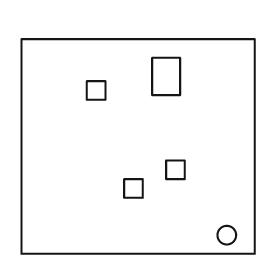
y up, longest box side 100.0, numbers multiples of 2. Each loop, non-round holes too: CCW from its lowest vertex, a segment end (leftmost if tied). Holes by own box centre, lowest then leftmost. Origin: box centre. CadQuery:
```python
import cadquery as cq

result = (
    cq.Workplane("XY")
    .moveTo(-50.0, -46.0)
    .lineTo(50.0, -46.0)
    .lineTo(50.0, 46.0)
    .lineTo(-50.0, 46.0)
    .close()
    .moveTo(38.0, -38.0)
    .circle(4.0)
    .moveTo(-6.0, -22.0)
    .lineTo(2.0, -22.0)
    .lineTo(2.0, -14.0)
    .lineTo(-6.0, -14.0)
    .close()
    .moveTo(12.0, -14.0)
    .lineTo(20.0, -14.0)
    .lineTo(20.0, -6.0)
    .lineTo(12.0, -6.0)
    .close()
    .moveTo(-22.0, 20.0)
    .lineTo(-14.0, 20.0)
    .lineTo(-14.0, 28.0)
    .lineTo(-22.0, 28.0)
    .close()
    .moveTo(6.0, 22.0)
    .lineTo(18.0, 22.0)
    .lineTo(18.0, 38.0)
    .lineTo(6.0, 38.0)
    .close()
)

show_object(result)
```